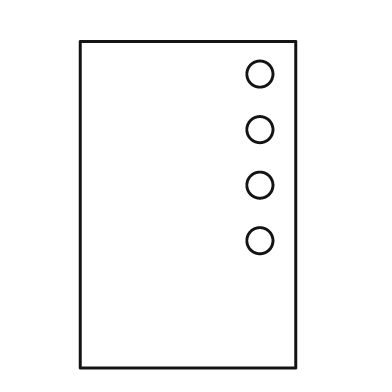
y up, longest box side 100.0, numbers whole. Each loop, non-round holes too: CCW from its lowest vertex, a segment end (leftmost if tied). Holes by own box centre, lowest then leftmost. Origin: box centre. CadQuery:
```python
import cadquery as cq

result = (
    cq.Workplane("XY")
    .moveTo(-33.0, -50.0)
    .lineTo(33.0, -50.0)
    .lineTo(33.0, 50.0)
    .lineTo(-33.0, 50.0)
    .close()
    .moveTo(22.0, -11.0)
    .circle(4.0)
    .moveTo(22.0, 6.0)
    .circle(4.0)
    .moveTo(22.0, 23.0)
    .circle(4.0)
    .moveTo(22.0, 40.0)
    .circle(4.0)
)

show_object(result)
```